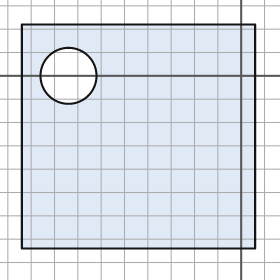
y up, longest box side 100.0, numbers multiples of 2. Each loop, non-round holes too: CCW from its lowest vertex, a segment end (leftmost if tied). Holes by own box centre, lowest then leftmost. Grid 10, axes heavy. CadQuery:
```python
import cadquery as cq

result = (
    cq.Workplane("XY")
    .moveTo(-94.0, -74.0)
    .lineTo(6.0, -74.0)
    .lineTo(6.0, 22.0)
    .lineTo(-94.0, 22.0)
    .close()
    .moveTo(-74.0, 0.0)
    .circle(12.0)
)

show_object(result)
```